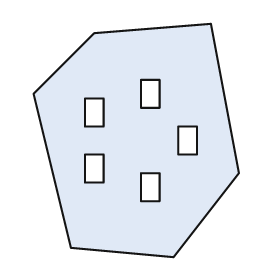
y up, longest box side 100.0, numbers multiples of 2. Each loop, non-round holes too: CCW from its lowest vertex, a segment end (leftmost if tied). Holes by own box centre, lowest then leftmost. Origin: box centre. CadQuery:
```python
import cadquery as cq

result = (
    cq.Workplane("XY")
    .moveTo(16.0, -50.0)
    .lineTo(44.0, -14.0)
    .lineTo(32.0, 50.0)
    .lineTo(-18.0, 46.0)
    .lineTo(-44.0, 20.0)
    .lineTo(-28.0, -46.0)
    .close()
    .moveTo(2.0, -26.0)
    .lineTo(10.0, -26.0)
    .lineTo(10.0, -14.0)
    .lineTo(2.0, -14.0)
    .close()
    .moveTo(-22.0, -18.0)
    .lineTo(-14.0, -18.0)
    .lineTo(-14.0, -6.0)
    .lineTo(-22.0, -6.0)
    .close()
    .moveTo(18.0, -6.0)
    .lineTo(26.0, -6.0)
    .lineTo(26.0, 6.0)
    .lineTo(18.0, 6.0)
    .close()
    .moveTo(-22.0, 6.0)
    .lineTo(-14.0, 6.0)
    .lineTo(-14.0, 18.0)
    .lineTo(-22.0, 18.0)
    .close()
    .moveTo(2.0, 14.0)
    .lineTo(10.0, 14.0)
    .lineTo(10.0, 26.0)
    .lineTo(2.0, 26.0)
    .close()
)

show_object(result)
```